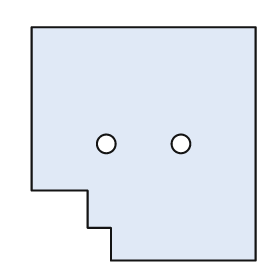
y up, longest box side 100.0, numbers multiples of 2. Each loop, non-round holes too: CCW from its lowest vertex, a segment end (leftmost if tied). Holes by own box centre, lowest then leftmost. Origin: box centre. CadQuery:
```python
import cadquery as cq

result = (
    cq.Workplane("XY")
    .moveTo(-14.0, -50.0)
    .lineTo(48.0, -50.0)
    .lineTo(48.0, 50.0)
    .lineTo(-48.0, 50.0)
    .lineTo(-48.0, -20.0)
    .lineTo(-24.0, -20.0)
    .lineTo(-24.0, -36.0)
    .lineTo(-14.0, -36.0)
    .close()
    .moveTo(-16.0, 0.0)
    .circle(4.0)
    .moveTo(16.0, 0.0)
    .circle(4.0)
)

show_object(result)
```